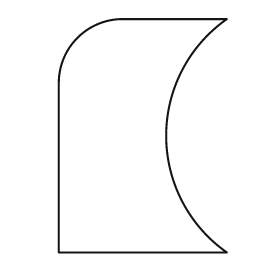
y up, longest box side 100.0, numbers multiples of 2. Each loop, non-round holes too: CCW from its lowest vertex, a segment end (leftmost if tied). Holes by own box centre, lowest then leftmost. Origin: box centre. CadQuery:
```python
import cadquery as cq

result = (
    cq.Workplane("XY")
    .moveTo(-36.0, -50.0)
    .lineTo(36.0, -50.0)
    .threePointArc((10.0, 0.0), (36.0, 50.0))
    .lineTo(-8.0, 50.0)
    .threePointArc((-28.0, 42.0), (-36.0, 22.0))
    .close()
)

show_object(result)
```